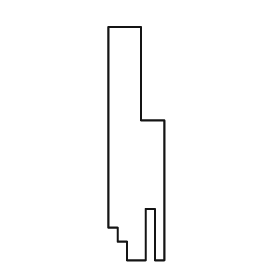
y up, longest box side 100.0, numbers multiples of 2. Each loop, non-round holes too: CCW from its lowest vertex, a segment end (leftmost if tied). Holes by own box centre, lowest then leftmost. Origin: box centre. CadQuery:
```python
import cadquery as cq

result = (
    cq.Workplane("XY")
    .moveTo(-4.0, -50.0)
    .lineTo(4.0, -50.0)
    .lineTo(4.0, -28.0)
    .lineTo(8.0, -28.0)
    .lineTo(8.0, -50.0)
    .lineTo(12.0, -50.0)
    .lineTo(12.0, 10.0)
    .lineTo(2.0, 10.0)
    .lineTo(2.0, 50.0)
    .lineTo(-12.0, 50.0)
    .lineTo(-12.0, -36.0)
    .lineTo(-8.0, -36.0)
    .lineTo(-8.0, -42.0)
    .lineTo(-4.0, -42.0)
    .close()
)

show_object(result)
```